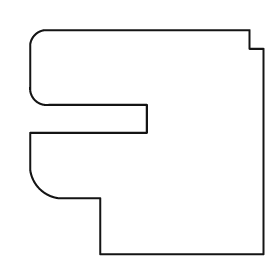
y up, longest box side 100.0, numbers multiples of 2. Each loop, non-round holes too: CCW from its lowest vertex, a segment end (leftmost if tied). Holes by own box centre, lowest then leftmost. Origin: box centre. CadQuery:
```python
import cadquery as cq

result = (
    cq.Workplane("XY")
    .moveTo(-20.0, -48.0)
    .lineTo(50.0, -48.0)
    .lineTo(50.0, 40.0)
    .lineTo(44.0, 40.0)
    .lineTo(44.0, 48.0)
    .lineTo(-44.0, 48.0)
    .threePointArc((-48.0, 46.0), (-50.0, 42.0))
    .lineTo(-50.0, 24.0)
    .threePointArc((-48.0, 18.0), (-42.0, 16.0))
    .lineTo(0.0, 16.0)
    .lineTo(0.0, 4.0)
    .lineTo(-50.0, 4.0)
    .lineTo(-50.0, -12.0)
    .threePointArc((-46.0, -20.0), (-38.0, -24.0))
    .lineTo(-20.0, -24.0)
    .close()
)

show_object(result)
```